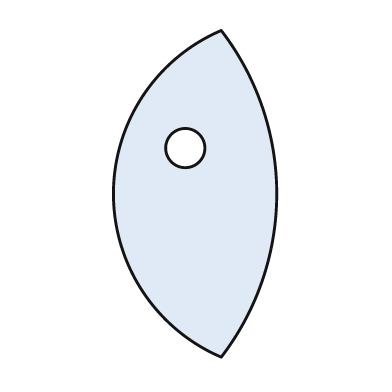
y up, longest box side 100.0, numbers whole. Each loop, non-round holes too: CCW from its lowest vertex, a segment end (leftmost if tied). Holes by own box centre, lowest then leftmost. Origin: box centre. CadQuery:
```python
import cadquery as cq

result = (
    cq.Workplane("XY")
    .moveTo(8.0, -50.0)
    .threePointArc((25.0, 0.0), (8.0, 50.0))
    .threePointArc((-25.0, 0.0), (8.0, -50.0))
    .close()
    .moveTo(-3.0, 14.0)
    .circle(6.0)
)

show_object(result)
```